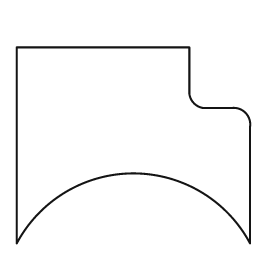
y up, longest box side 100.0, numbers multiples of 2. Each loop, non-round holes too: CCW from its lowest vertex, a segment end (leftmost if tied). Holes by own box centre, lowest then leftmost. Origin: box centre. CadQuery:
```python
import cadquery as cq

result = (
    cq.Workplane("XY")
    .moveTo(-50.0, -42.0)
    .threePointArc((0.0, -12.0), (50.0, -42.0))
    .lineTo(50.0, 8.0)
    .threePointArc((48.0, 14.0), (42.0, 16.0))
    .lineTo(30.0, 16.0)
    .threePointArc((26.0, 18.0), (24.0, 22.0))
    .lineTo(24.0, 42.0)
    .lineTo(-50.0, 42.0)
    .close()
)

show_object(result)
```